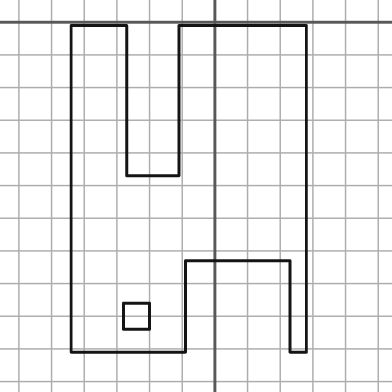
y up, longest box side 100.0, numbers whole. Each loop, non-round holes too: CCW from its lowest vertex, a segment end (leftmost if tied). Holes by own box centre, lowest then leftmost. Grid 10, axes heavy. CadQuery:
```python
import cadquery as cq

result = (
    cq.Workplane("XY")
    .moveTo(-44.0, -101.0)
    .lineTo(-9.0, -101.0)
    .lineTo(-9.0, -73.0)
    .lineTo(23.0, -73.0)
    .lineTo(23.0, -101.0)
    .lineTo(28.0, -101.0)
    .lineTo(28.0, -1.0)
    .lineTo(-11.0, -1.0)
    .lineTo(-11.0, -47.0)
    .lineTo(-27.0, -47.0)
    .lineTo(-27.0, -1.0)
    .lineTo(-44.0, -1.0)
    .close()
    .moveTo(-28.0, -94.0)
    .lineTo(-20.0, -94.0)
    .lineTo(-20.0, -86.0)
    .lineTo(-28.0, -86.0)
    .close()
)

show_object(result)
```